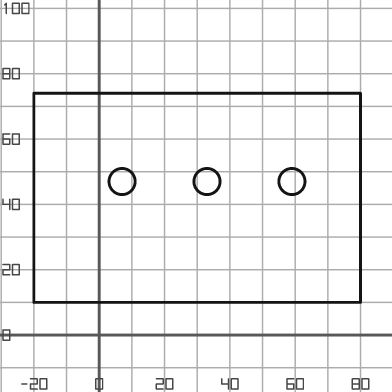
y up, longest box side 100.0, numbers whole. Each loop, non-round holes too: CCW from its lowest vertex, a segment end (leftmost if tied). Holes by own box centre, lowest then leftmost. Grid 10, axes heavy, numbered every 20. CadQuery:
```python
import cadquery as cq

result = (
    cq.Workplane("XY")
    .moveTo(-20.0, 10.0)
    .lineTo(80.0, 10.0)
    .lineTo(80.0, 74.0)
    .lineTo(-20.0, 74.0)
    .close()
    .moveTo(7.0, 47.0)
    .circle(4.0)
    .moveTo(33.0, 47.0)
    .circle(4.0)
    .moveTo(59.0, 47.0)
    .circle(4.0)
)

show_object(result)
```